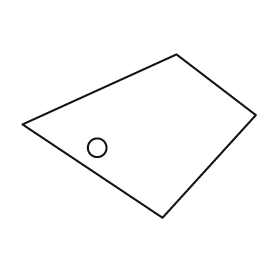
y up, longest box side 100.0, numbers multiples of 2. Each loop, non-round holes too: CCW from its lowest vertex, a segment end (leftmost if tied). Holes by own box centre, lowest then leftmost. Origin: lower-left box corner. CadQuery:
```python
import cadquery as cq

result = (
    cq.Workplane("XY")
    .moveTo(60.0, 0.0)
    .lineTo(100.0, 44.0)
    .lineTo(66.0, 70.0)
    .lineTo(0.0, 40.0)
    .close()
    .moveTo(32.0, 30.0)
    .circle(4.0)
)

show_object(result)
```